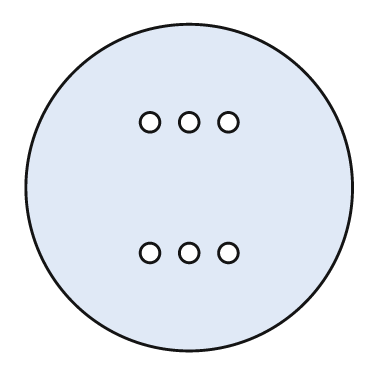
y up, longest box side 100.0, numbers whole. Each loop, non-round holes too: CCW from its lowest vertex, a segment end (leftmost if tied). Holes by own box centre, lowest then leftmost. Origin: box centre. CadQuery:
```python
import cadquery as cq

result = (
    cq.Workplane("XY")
    .moveTo(0.0, 0.0)
    .circle(50.0)
    .moveTo(-12.0, -20.0)
    .circle(3.0)
    .moveTo(0.0, -20.0)
    .circle(3.0)
    .moveTo(12.0, -20.0)
    .circle(3.0)
    .moveTo(-12.0, 20.0)
    .circle(3.0)
    .moveTo(0.0, 20.0)
    .circle(3.0)
    .moveTo(12.0, 20.0)
    .circle(3.0)
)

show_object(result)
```